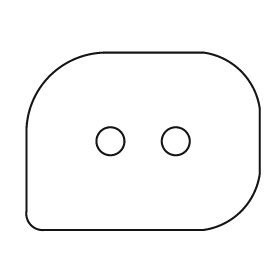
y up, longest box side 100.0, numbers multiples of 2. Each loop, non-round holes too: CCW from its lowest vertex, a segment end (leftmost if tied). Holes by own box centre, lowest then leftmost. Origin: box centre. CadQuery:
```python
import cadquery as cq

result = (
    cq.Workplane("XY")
    .moveTo(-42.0, -38.0)
    .lineTo(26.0, -38.0)
    .threePointArc((42.0, -30.0), (50.0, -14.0))
    .lineTo(50.0, 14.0)
    .threePointArc((42.0, 30.0), (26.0, 38.0))
    .lineTo(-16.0, 38.0)
    .threePointArc((-40.0, 28.0), (-50.0, 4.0))
    .lineTo(-50.0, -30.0)
    .threePointArc((-48.0, -36.0), (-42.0, -38.0))
    .close()
    .moveTo(-14.0, 0.0)
    .circle(6.0)
    .moveTo(14.0, 0.0)
    .circle(6.0)
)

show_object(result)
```